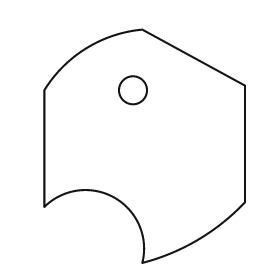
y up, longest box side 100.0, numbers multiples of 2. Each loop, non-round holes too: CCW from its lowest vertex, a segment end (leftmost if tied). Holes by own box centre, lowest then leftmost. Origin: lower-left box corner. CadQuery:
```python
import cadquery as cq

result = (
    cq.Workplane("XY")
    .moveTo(42.0, 0.0)
    .threePointArc((66.0, 10.0), (86.0, 26.0))
    .lineTo(86.0, 76.0)
    .lineTo(42.0, 100.0)
    .threePointArc((18.0, 92.0), (0.0, 74.0))
    .lineTo(0.0, 24.0)
    .threePointArc((30.0, 28.0), (42.0, 0.0))
    .close()
    .moveTo(38.0, 74.0)
    .circle(6.0)
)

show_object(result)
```